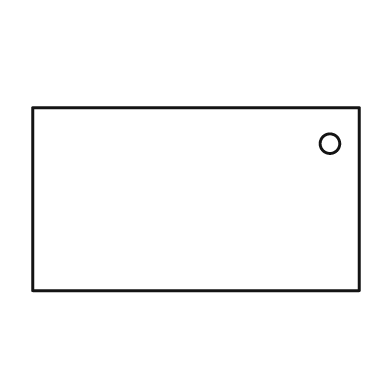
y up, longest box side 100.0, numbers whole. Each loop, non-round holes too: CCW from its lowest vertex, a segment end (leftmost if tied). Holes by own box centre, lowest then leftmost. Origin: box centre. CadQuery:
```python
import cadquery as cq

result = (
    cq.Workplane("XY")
    .moveTo(-50.0, -28.0)
    .lineTo(50.0, -28.0)
    .lineTo(50.0, 28.0)
    .lineTo(-50.0, 28.0)
    .close()
    .moveTo(41.0, 17.0)
    .circle(3.0)
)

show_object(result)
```